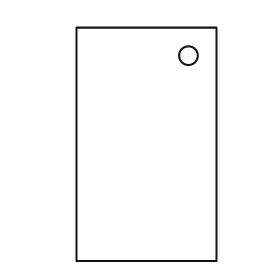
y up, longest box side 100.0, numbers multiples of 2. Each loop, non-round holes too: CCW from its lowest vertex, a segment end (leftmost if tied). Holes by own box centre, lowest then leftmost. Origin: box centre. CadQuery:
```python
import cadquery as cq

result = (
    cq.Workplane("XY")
    .moveTo(-30.0, -50.0)
    .lineTo(30.0, -50.0)
    .lineTo(30.0, 50.0)
    .lineTo(-30.0, 50.0)
    .close()
    .moveTo(18.0, 38.0)
    .circle(4.0)
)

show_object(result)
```